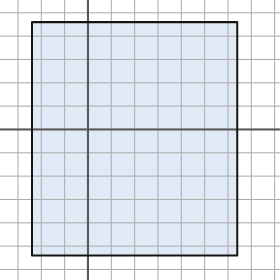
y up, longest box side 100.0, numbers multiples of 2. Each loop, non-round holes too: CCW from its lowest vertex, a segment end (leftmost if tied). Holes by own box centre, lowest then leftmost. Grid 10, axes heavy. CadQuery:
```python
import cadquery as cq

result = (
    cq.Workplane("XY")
    .moveTo(-24.0, -54.0)
    .lineTo(64.0, -54.0)
    .lineTo(64.0, 46.0)
    .lineTo(-24.0, 46.0)
    .close()
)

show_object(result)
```